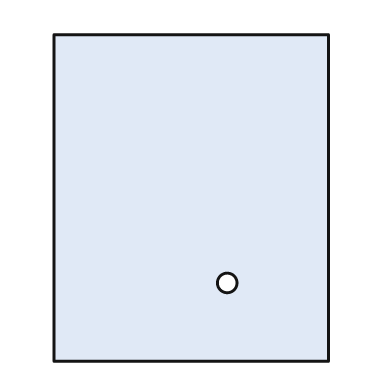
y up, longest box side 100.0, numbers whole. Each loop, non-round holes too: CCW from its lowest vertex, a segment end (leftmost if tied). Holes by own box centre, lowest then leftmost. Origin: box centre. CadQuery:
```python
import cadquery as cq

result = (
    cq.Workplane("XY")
    .moveTo(-42.0, -50.0)
    .lineTo(42.0, -50.0)
    .lineTo(42.0, 50.0)
    .lineTo(-42.0, 50.0)
    .close()
    .moveTo(11.0, -26.0)
    .circle(3.0)
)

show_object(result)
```